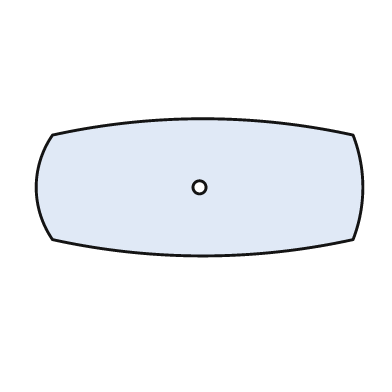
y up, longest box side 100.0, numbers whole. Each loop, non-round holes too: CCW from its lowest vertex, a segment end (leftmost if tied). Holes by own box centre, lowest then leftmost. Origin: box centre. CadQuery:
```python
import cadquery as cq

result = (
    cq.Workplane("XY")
    .moveTo(-45.0, -16.0)
    .threePointArc((1.0, -21.0), (47.0, -16.0))
    .threePointArc((50.0, 0.0), (47.0, 16.0))
    .threePointArc((1.0, 21.0), (-45.0, 16.0))
    .threePointArc((-50.0, 0.0), (-45.0, -16.0))
    .close()
    .moveTo(0.0, 0.0)
    .circle(2.0)
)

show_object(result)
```